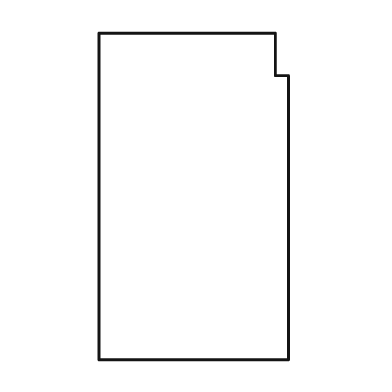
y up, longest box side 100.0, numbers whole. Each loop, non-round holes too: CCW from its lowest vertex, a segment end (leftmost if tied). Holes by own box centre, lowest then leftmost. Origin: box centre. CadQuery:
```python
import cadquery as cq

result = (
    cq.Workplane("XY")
    .moveTo(-29.0, -50.0)
    .lineTo(29.0, -50.0)
    .lineTo(29.0, 37.0)
    .lineTo(25.0, 37.0)
    .lineTo(25.0, 50.0)
    .lineTo(-29.0, 50.0)
    .close()
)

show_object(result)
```